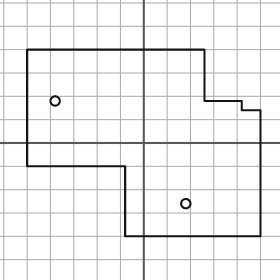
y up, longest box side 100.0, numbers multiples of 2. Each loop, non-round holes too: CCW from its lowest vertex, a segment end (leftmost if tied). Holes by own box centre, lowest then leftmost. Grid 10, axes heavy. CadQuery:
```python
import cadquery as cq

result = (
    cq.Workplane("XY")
    .moveTo(-8.0, -40.0)
    .lineTo(50.0, -40.0)
    .lineTo(50.0, 14.0)
    .lineTo(42.0, 14.0)
    .lineTo(42.0, 18.0)
    .lineTo(26.0, 18.0)
    .lineTo(26.0, 40.0)
    .lineTo(-50.0, 40.0)
    .lineTo(-50.0, -10.0)
    .lineTo(-8.0, -10.0)
    .close()
    .moveTo(18.0, -26.0)
    .circle(2.0)
    .moveTo(-38.0, 18.0)
    .circle(2.0)
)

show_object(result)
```